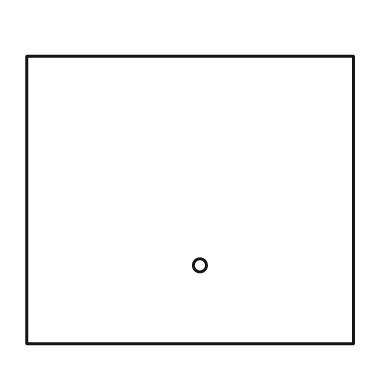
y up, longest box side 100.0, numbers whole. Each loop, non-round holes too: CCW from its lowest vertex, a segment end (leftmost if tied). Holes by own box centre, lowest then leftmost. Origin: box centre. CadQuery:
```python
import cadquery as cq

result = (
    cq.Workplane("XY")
    .moveTo(-50.0, -44.0)
    .lineTo(50.0, -44.0)
    .lineTo(50.0, 44.0)
    .lineTo(-50.0, 44.0)
    .close()
    .moveTo(3.0, -20.0)
    .circle(2.0)
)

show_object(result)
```